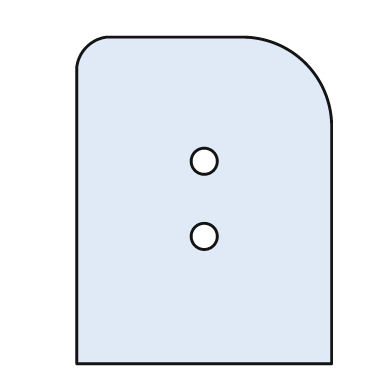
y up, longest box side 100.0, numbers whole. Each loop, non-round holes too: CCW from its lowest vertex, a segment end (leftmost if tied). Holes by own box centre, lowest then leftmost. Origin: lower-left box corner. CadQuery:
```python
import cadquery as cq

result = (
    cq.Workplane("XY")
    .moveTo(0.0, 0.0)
    .lineTo(78.0, 0.0)
    .lineTo(78.0, 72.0)
    .threePointArc((70.0, 92.0), (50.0, 100.0))
    .lineTo(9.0, 100.0)
    .threePointArc((3.0, 97.0), (0.0, 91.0))
    .close()
    .moveTo(39.0, 39.0)
    .circle(4.0)
    .moveTo(39.0, 62.0)
    .circle(4.0)
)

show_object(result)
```